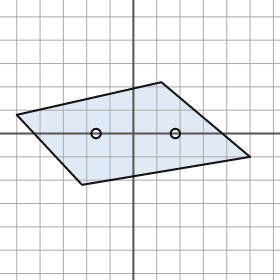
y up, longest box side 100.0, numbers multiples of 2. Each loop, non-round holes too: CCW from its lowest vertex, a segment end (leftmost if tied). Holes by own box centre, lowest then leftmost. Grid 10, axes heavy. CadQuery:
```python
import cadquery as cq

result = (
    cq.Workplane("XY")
    .moveTo(-22.0, -22.0)
    .lineTo(50.0, -10.0)
    .lineTo(12.0, 22.0)
    .lineTo(-50.0, 8.0)
    .close()
    .moveTo(-16.0, 0.0)
    .circle(2.0)
    .moveTo(18.0, 0.0)
    .circle(2.0)
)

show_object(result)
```